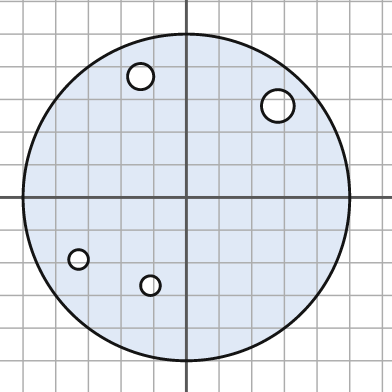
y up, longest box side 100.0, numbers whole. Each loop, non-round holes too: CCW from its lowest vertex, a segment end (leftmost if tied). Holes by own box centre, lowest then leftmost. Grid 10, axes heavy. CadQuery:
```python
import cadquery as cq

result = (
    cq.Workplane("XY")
    .moveTo(0.0, 0.0)
    .circle(50.0)
    .moveTo(-11.0, -27.0)
    .circle(3.0)
    .moveTo(-33.0, -19.0)
    .circle(3.0)
    .moveTo(28.0, 28.0)
    .circle(5.0)
    .moveTo(-14.0, 37.0)
    .circle(4.0)
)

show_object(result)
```